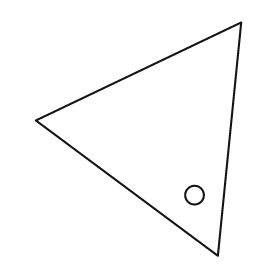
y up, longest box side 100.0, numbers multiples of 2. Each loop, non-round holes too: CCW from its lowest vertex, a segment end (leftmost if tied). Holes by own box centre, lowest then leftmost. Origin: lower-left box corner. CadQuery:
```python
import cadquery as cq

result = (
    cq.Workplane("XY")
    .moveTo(78.0, 0.0)
    .lineTo(88.0, 100.0)
    .lineTo(0.0, 58.0)
    .close()
    .moveTo(68.0, 26.0)
    .circle(4.0)
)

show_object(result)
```